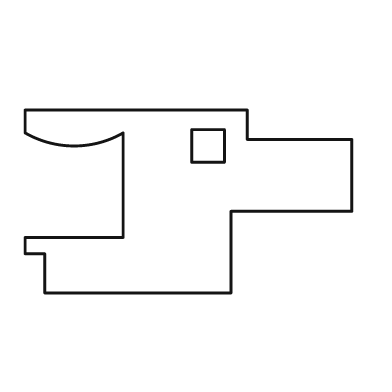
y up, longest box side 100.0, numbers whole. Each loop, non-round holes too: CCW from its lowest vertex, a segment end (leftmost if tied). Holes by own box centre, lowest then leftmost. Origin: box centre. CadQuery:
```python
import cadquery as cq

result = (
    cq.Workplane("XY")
    .moveTo(-44.0, -28.0)
    .lineTo(13.0, -28.0)
    .lineTo(13.0, -3.0)
    .lineTo(50.0, -3.0)
    .lineTo(50.0, 19.0)
    .lineTo(18.0, 19.0)
    .lineTo(18.0, 28.0)
    .lineTo(-50.0, 28.0)
    .lineTo(-50.0, 21.0)
    .threePointArc((-35.0, 17.0), (-20.0, 21.0))
    .lineTo(-20.0, -11.0)
    .lineTo(-50.0, -11.0)
    .lineTo(-50.0, -16.0)
    .lineTo(-44.0, -16.0)
    .close()
    .moveTo(1.0, 12.0)
    .lineTo(11.0, 12.0)
    .lineTo(11.0, 22.0)
    .lineTo(1.0, 22.0)
    .close()
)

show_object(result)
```